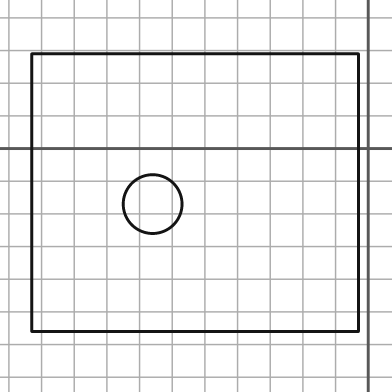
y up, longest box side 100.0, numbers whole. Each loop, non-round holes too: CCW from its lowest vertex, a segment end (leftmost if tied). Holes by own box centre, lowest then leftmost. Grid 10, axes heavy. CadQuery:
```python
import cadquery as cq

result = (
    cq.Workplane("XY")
    .moveTo(-103.0, -56.0)
    .lineTo(-3.0, -56.0)
    .lineTo(-3.0, 29.0)
    .lineTo(-103.0, 29.0)
    .close()
    .moveTo(-66.0, -17.0)
    .circle(9.0)
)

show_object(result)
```